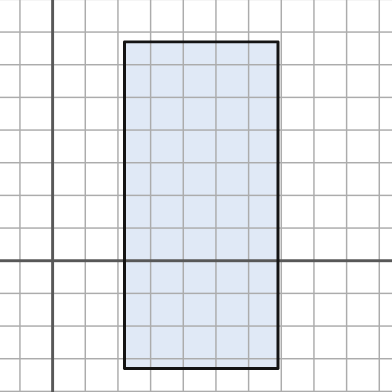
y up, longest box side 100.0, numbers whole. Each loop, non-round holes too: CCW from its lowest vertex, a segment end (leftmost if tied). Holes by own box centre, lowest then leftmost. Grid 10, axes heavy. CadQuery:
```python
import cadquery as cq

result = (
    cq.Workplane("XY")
    .moveTo(22.0, -33.0)
    .lineTo(69.0, -33.0)
    .lineTo(69.0, 67.0)
    .lineTo(22.0, 67.0)
    .close()
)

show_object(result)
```